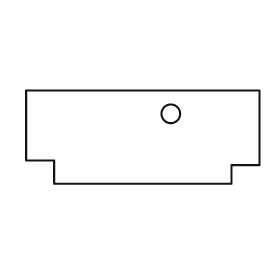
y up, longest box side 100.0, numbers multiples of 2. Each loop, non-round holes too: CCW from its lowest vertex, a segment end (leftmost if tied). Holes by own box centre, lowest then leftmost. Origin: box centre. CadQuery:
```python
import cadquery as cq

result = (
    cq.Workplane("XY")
    .moveTo(-38.0, -20.0)
    .lineTo(38.0, -20.0)
    .lineTo(38.0, -12.0)
    .lineTo(50.0, -12.0)
    .lineTo(50.0, 20.0)
    .lineTo(-50.0, 20.0)
    .lineTo(-50.0, -10.0)
    .lineTo(-38.0, -10.0)
    .close()
    .moveTo(12.0, 10.0)
    .circle(4.0)
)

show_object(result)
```